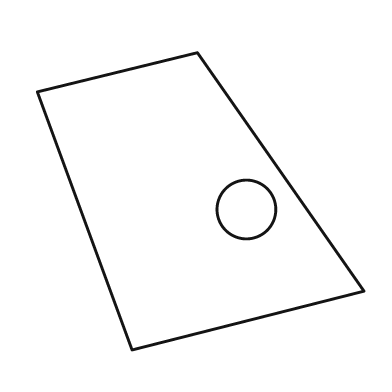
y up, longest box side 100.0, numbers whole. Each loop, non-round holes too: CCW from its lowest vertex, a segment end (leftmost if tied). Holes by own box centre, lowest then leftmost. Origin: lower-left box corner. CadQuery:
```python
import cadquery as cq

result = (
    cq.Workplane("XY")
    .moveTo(29.0, 0.0)
    .lineTo(100.0, 18.0)
    .lineTo(49.0, 91.0)
    .lineTo(0.0, 79.0)
    .close()
    .moveTo(64.0, 43.0)
    .circle(9.0)
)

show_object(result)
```